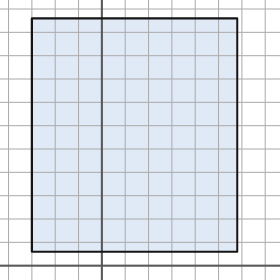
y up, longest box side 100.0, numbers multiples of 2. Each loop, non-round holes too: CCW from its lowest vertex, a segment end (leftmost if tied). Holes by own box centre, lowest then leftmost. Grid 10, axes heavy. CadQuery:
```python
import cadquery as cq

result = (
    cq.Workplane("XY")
    .moveTo(-30.0, 6.0)
    .lineTo(58.0, 6.0)
    .lineTo(58.0, 106.0)
    .lineTo(-30.0, 106.0)
    .close()
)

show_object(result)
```